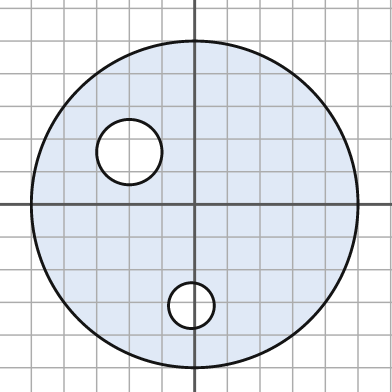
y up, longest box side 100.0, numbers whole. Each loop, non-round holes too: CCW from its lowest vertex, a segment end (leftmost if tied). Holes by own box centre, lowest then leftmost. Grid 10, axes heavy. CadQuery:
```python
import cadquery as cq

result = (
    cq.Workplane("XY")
    .moveTo(0.0, 0.0)
    .circle(50.0)
    .moveTo(-1.0, -31.0)
    .circle(7.0)
    .moveTo(-20.0, 16.0)
    .circle(10.0)
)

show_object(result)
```